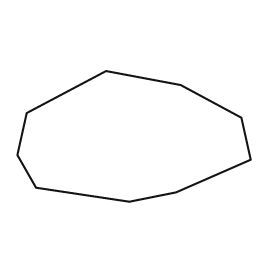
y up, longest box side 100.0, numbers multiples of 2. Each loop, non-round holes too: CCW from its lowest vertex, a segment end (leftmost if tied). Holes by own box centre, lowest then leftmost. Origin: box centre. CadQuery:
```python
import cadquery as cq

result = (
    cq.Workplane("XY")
    .moveTo(-2.0, -28.0)
    .lineTo(18.0, -24.0)
    .lineTo(50.0, -10.0)
    .lineTo(46.0, 8.0)
    .lineTo(20.0, 22.0)
    .lineTo(-12.0, 28.0)
    .lineTo(-46.0, 10.0)
    .lineTo(-50.0, -8.0)
    .lineTo(-42.0, -22.0)
    .close()
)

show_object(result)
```